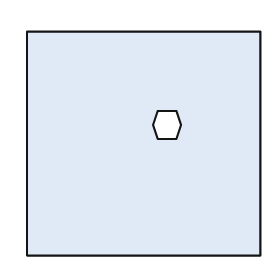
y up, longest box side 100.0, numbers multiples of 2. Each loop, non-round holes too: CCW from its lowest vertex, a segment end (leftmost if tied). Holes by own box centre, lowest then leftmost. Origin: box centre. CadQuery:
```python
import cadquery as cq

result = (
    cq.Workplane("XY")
    .moveTo(-50.0, -48.0)
    .lineTo(50.0, -48.0)
    .lineTo(50.0, 48.0)
    .lineTo(-50.0, 48.0)
    .close()
    .moveTo(6.0, 2.0)
    .lineTo(14.0, 2.0)
    .lineTo(16.0, 8.0)
    .lineTo(14.0, 14.0)
    .lineTo(6.0, 14.0)
    .lineTo(4.0, 8.0)
    .close()
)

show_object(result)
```